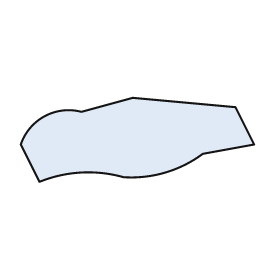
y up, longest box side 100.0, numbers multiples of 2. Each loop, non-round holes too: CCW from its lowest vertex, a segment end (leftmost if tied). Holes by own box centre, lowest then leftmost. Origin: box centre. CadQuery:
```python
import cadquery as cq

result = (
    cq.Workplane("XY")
    .moveTo(-42.0, -18.0)
    .threePointArc((-24.0, -14.0), (-6.0, -16.0))
    .threePointArc((12.0, -14.0), (28.0, -6.0))
    .lineTo(50.0, -2.0)
    .lineTo(42.0, 14.0)
    .lineTo(-2.0, 18.0)
    .lineTo(-24.0, 12.0)
    .threePointArc((-40.0, 10.0), (-50.0, -2.0))
    .close()
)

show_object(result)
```